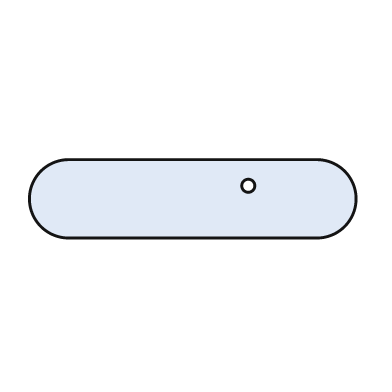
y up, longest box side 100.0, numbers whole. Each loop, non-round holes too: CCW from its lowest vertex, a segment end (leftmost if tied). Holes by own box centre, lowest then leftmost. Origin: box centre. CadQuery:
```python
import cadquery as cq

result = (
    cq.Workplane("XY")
    .moveTo(-38.0, -12.0)
    .lineTo(38.0, -12.0)
    .threePointArc((50.0, 0.0), (38.0, 12.0))
    .lineTo(-38.0, 12.0)
    .threePointArc((-50.0, 0.0), (-38.0, -12.0))
    .close()
    .moveTo(17.0, 4.0)
    .circle(2.0)
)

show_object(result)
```